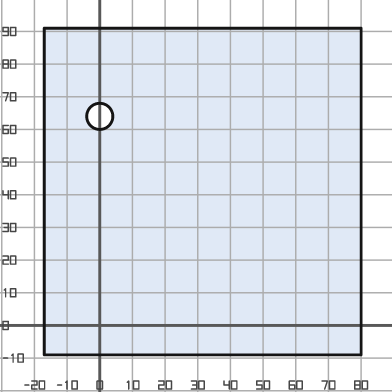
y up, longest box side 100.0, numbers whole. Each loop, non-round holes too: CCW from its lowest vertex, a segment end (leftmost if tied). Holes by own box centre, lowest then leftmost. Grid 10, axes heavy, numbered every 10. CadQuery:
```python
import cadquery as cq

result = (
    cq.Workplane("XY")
    .moveTo(-17.0, -9.0)
    .lineTo(80.0, -9.0)
    .lineTo(80.0, 91.0)
    .lineTo(-17.0, 91.0)
    .close()
    .moveTo(0.0, 64.0)
    .circle(4.0)
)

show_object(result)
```